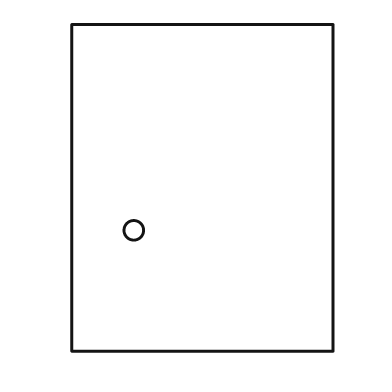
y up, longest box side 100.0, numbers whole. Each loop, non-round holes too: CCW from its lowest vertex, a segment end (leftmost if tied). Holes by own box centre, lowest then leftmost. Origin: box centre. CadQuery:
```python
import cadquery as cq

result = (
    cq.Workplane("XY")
    .moveTo(-40.0, -50.0)
    .lineTo(40.0, -50.0)
    .lineTo(40.0, 50.0)
    .lineTo(-40.0, 50.0)
    .close()
    .moveTo(-21.0, -13.0)
    .circle(3.0)
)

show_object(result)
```